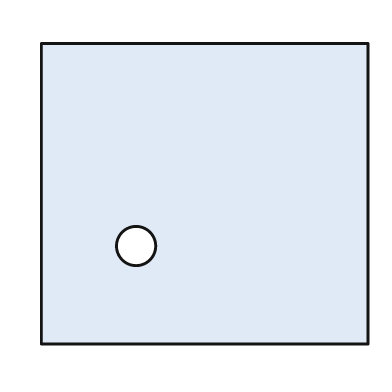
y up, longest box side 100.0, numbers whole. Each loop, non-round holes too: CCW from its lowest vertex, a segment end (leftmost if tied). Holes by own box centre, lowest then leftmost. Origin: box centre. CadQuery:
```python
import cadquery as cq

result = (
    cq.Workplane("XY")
    .moveTo(-50.0, -46.0)
    .lineTo(50.0, -46.0)
    .lineTo(50.0, 46.0)
    .lineTo(-50.0, 46.0)
    .close()
    .moveTo(-21.0, -16.0)
    .circle(6.0)
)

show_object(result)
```